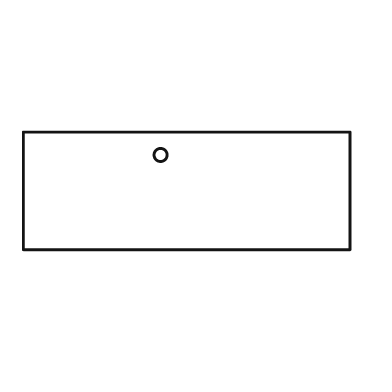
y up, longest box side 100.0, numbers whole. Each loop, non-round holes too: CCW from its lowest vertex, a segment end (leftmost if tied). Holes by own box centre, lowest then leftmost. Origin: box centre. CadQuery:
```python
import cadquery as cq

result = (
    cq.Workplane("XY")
    .moveTo(-50.0, -18.0)
    .lineTo(50.0, -18.0)
    .lineTo(50.0, 18.0)
    .lineTo(-50.0, 18.0)
    .close()
    .moveTo(-8.0, 11.0)
    .circle(2.0)
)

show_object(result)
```